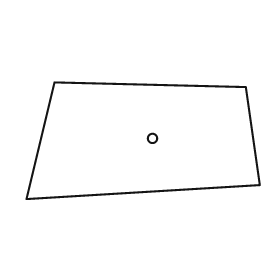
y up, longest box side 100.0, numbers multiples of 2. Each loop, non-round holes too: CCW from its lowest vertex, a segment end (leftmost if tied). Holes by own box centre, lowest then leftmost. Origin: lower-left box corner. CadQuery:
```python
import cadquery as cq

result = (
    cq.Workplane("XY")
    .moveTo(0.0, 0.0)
    .lineTo(100.0, 6.0)
    .lineTo(94.0, 48.0)
    .lineTo(12.0, 50.0)
    .close()
    .moveTo(54.0, 26.0)
    .circle(2.0)
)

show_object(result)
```